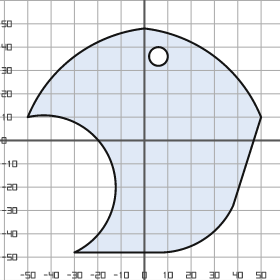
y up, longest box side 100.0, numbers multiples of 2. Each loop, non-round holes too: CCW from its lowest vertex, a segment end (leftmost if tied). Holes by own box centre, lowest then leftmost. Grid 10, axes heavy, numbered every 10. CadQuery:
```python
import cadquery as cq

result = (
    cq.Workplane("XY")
    .moveTo(-30.0, -48.0)
    .lineTo(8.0, -48.0)
    .threePointArc((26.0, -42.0), (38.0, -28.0))
    .lineTo(50.0, 10.0)
    .threePointArc((30.0, 36.0), (0.0, 48.0))
    .threePointArc((-30.0, 36.0), (-50.0, 10.0))
    .threePointArc((-14.0, -10.0), (-30.0, -48.0))
    .close()
    .moveTo(6.0, 36.0)
    .circle(4.0)
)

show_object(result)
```